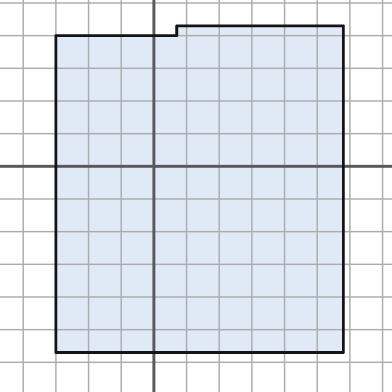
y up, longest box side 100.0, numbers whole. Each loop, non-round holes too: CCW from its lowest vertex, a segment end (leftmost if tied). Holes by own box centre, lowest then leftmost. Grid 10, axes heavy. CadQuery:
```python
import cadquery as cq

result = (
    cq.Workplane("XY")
    .moveTo(-30.0, -57.0)
    .lineTo(58.0, -57.0)
    .lineTo(58.0, 43.0)
    .lineTo(7.0, 43.0)
    .lineTo(7.0, 40.0)
    .lineTo(-30.0, 40.0)
    .close()
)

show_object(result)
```